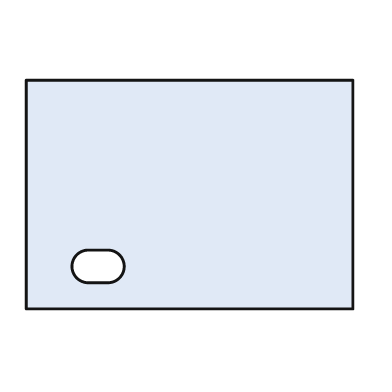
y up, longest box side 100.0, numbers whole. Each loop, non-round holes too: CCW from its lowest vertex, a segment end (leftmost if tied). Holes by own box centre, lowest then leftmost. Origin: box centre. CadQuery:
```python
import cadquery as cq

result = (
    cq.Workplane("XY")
    .moveTo(-50.0, -35.0)
    .lineTo(50.0, -35.0)
    .lineTo(50.0, 35.0)
    .lineTo(-50.0, 35.0)
    .close()
    .moveTo(-31.0, -27.0)
    .lineTo(-25.0, -27.0)
    .threePointArc((-20.0, -22.0), (-25.0, -17.0))
    .lineTo(-31.0, -17.0)
    .threePointArc((-36.0, -22.0), (-31.0, -27.0))
    .close()
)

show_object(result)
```